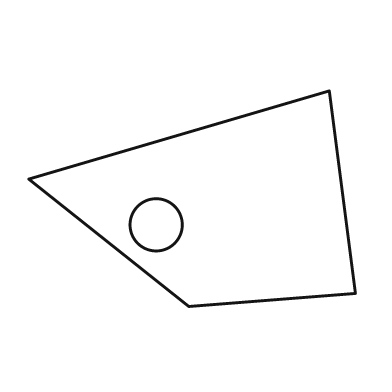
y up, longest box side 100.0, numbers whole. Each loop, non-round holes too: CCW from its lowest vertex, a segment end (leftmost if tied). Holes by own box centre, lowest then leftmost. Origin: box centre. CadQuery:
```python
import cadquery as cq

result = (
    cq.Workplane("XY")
    .moveTo(-1.0, -33.0)
    .lineTo(50.0, -29.0)
    .lineTo(42.0, 33.0)
    .lineTo(-50.0, 6.0)
    .close()
    .moveTo(-11.0, -8.0)
    .circle(8.0)
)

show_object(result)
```